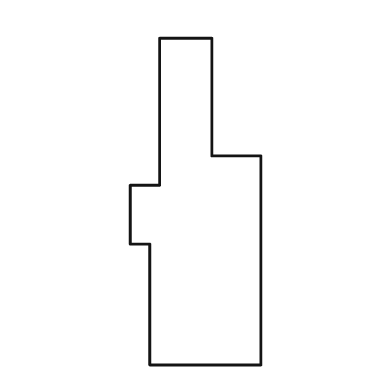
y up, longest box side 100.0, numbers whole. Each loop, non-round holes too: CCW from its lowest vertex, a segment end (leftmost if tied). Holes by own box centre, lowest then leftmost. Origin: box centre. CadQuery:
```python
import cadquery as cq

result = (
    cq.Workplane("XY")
    .moveTo(-14.0, -50.0)
    .lineTo(20.0, -50.0)
    .lineTo(20.0, 14.0)
    .lineTo(5.0, 14.0)
    .lineTo(5.0, 50.0)
    .lineTo(-11.0, 50.0)
    .lineTo(-11.0, 5.0)
    .lineTo(-20.0, 5.0)
    .lineTo(-20.0, -13.0)
    .lineTo(-14.0, -13.0)
    .close()
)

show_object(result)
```